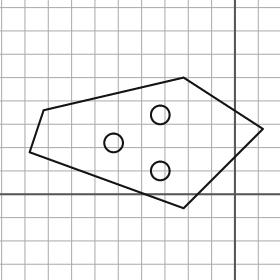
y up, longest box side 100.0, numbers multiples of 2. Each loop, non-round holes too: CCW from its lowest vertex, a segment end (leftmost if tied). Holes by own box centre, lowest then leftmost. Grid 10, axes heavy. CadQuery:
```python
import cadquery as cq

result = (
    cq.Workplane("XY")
    .moveTo(-22.0, -6.0)
    .lineTo(12.0, 28.0)
    .lineTo(-22.0, 50.0)
    .lineTo(-82.0, 36.0)
    .lineTo(-88.0, 18.0)
    .close()
    .moveTo(-32.0, 10.0)
    .circle(4.0)
    .moveTo(-52.0, 22.0)
    .circle(4.0)
    .moveTo(-32.0, 34.0)
    .circle(4.0)
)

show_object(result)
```